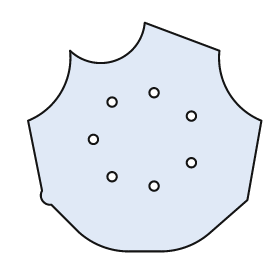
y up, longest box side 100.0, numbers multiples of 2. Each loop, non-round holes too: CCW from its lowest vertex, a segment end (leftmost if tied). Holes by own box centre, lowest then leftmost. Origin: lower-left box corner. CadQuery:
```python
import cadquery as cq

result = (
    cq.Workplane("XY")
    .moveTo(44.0, 0.0)
    .lineTo(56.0, 0.0)
    .threePointArc((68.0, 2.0), (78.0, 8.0))
    .lineTo(94.0, 22.0)
    .lineTo(100.0, 56.0)
    .threePointArc((86.0, 68.0), (82.0, 86.0))
    .lineTo(50.0, 98.0)
    .threePointArc((38.0, 82.0), (18.0, 86.0))
    .threePointArc((14.0, 68.0), (0.0, 56.0))
    .lineTo(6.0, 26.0)
    .threePointArc((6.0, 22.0), (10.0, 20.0))
    .lineTo(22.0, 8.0)
    .threePointArc((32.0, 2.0), (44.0, 0.0))
    .close()
    .moveTo(54.0, 28.0)
    .circle(2.0)
    .moveTo(36.0, 32.0)
    .circle(2.0)
    .moveTo(70.0, 38.0)
    .circle(2.0)
    .moveTo(28.0, 48.0)
    .circle(2.0)
    .moveTo(70.0, 58.0)
    .circle(2.0)
    .moveTo(36.0, 64.0)
    .circle(2.0)
    .moveTo(54.0, 68.0)
    .circle(2.0)
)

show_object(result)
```